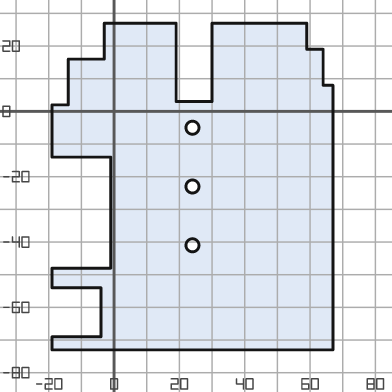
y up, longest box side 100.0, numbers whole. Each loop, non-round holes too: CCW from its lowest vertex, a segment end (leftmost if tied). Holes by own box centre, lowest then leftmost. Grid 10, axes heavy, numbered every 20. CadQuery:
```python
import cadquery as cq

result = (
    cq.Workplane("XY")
    .moveTo(-19.0, -73.0)
    .lineTo(67.0, -73.0)
    .lineTo(67.0, 8.0)
    .lineTo(64.0, 8.0)
    .lineTo(64.0, 19.0)
    .lineTo(59.0, 19.0)
    .lineTo(59.0, 27.0)
    .lineTo(30.0, 27.0)
    .lineTo(30.0, 3.0)
    .lineTo(19.0, 3.0)
    .lineTo(19.0, 27.0)
    .lineTo(-3.0, 27.0)
    .lineTo(-3.0, 16.0)
    .lineTo(-14.0, 16.0)
    .lineTo(-14.0, 2.0)
    .lineTo(-19.0, 2.0)
    .lineTo(-19.0, -14.0)
    .lineTo(-1.0, -14.0)
    .lineTo(-1.0, -48.0)
    .lineTo(-19.0, -48.0)
    .lineTo(-19.0, -54.0)
    .lineTo(-4.0, -54.0)
    .lineTo(-4.0, -69.0)
    .lineTo(-19.0, -69.0)
    .close()
    .moveTo(24.0, -41.0)
    .circle(2.0)
    .moveTo(24.0, -23.0)
    .circle(2.0)
    .moveTo(24.0, -5.0)
    .circle(2.0)
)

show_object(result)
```